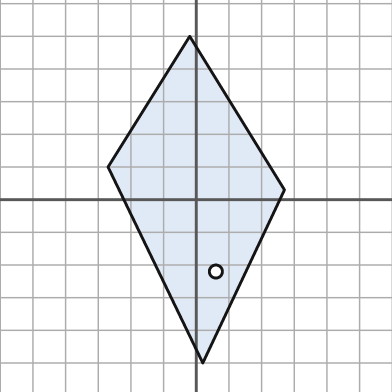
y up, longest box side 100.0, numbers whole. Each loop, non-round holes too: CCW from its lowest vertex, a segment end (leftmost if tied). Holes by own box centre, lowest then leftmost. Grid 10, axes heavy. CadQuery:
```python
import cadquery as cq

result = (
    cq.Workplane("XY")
    .moveTo(2.0, -50.0)
    .lineTo(27.0, 3.0)
    .lineTo(-2.0, 50.0)
    .lineTo(-27.0, 10.0)
    .close()
    .moveTo(6.0, -22.0)
    .circle(2.0)
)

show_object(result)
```